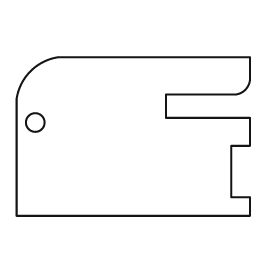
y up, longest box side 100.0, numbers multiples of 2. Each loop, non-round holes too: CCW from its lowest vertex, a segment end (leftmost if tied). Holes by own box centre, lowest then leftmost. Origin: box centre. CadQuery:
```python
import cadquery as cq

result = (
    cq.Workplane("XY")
    .moveTo(-50.0, -34.0)
    .lineTo(50.0, -34.0)
    .lineTo(50.0, -26.0)
    .lineTo(42.0, -26.0)
    .lineTo(42.0, -4.0)
    .lineTo(50.0, -4.0)
    .lineTo(50.0, 8.0)
    .lineTo(14.0, 8.0)
    .lineTo(14.0, 18.0)
    .lineTo(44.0, 18.0)
    .threePointArc((48.0, 20.0), (50.0, 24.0))
    .lineTo(50.0, 34.0)
    .lineTo(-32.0, 34.0)
    .threePointArc((-44.0, 28.0), (-50.0, 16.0))
    .close()
    .moveTo(-42.0, 6.0)
    .circle(4.0)
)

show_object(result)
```